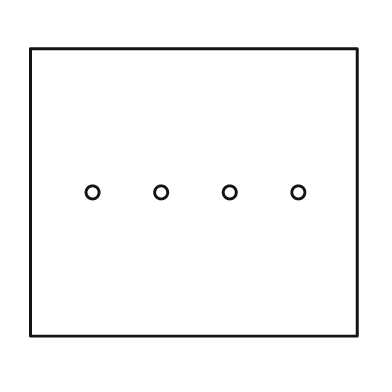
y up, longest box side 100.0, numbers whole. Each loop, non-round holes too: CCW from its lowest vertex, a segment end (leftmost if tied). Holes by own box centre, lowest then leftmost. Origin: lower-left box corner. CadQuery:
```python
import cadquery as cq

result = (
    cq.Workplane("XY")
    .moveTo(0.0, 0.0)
    .lineTo(100.0, 0.0)
    .lineTo(100.0, 88.0)
    .lineTo(0.0, 88.0)
    .close()
    .moveTo(19.0, 44.0)
    .circle(2.0)
    .moveTo(40.0, 44.0)
    .circle(2.0)
    .moveTo(61.0, 44.0)
    .circle(2.0)
    .moveTo(82.0, 44.0)
    .circle(2.0)
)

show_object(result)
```